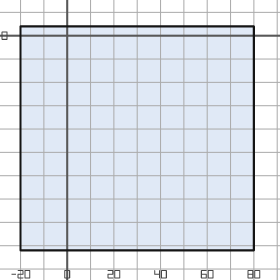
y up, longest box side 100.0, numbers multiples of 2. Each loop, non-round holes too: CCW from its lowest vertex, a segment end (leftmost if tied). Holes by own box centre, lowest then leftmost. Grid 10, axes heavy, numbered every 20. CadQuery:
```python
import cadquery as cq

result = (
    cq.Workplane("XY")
    .moveTo(-20.0, -92.0)
    .lineTo(80.0, -92.0)
    .lineTo(80.0, 4.0)
    .lineTo(-20.0, 4.0)
    .close()
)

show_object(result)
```